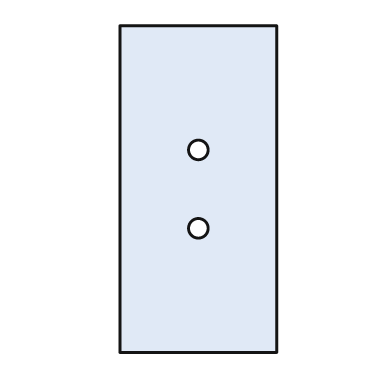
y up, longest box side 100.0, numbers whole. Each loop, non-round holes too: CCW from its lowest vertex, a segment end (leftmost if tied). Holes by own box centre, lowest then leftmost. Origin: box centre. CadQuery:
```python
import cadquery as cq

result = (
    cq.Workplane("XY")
    .moveTo(-24.0, -50.0)
    .lineTo(24.0, -50.0)
    .lineTo(24.0, 50.0)
    .lineTo(-24.0, 50.0)
    .close()
    .moveTo(0.0, -12.0)
    .circle(3.0)
    .moveTo(0.0, 12.0)
    .circle(3.0)
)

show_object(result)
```